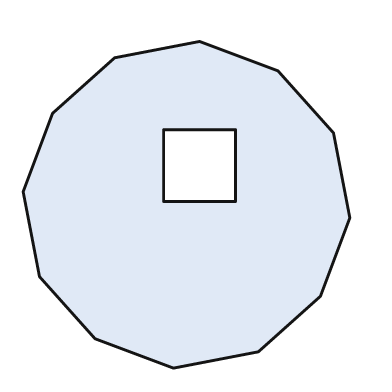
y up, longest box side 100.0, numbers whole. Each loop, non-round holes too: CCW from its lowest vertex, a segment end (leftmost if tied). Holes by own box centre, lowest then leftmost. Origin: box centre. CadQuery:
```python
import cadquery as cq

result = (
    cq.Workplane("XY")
    .moveTo(-4.0, -50.0)
    .lineTo(22.0, -45.0)
    .lineTo(41.0, -28.0)
    .lineTo(50.0, -4.0)
    .lineTo(45.0, 22.0)
    .lineTo(28.0, 41.0)
    .lineTo(4.0, 50.0)
    .lineTo(-22.0, 45.0)
    .lineTo(-41.0, 28.0)
    .lineTo(-50.0, 4.0)
    .lineTo(-45.0, -22.0)
    .lineTo(-28.0, -41.0)
    .close()
    .moveTo(-7.0, 1.0)
    .lineTo(15.0, 1.0)
    .lineTo(15.0, 23.0)
    .lineTo(-7.0, 23.0)
    .close()
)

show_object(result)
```